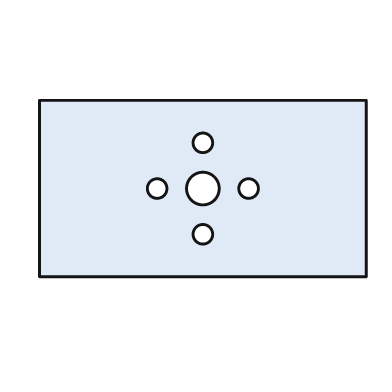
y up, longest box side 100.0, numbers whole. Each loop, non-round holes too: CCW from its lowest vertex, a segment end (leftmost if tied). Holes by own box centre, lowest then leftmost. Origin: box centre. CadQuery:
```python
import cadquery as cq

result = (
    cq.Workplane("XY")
    .moveTo(-50.0, -27.0)
    .lineTo(50.0, -27.0)
    .lineTo(50.0, 27.0)
    .lineTo(-50.0, 27.0)
    .close()
    .moveTo(0.0, -14.0)
    .circle(3.0)
    .moveTo(-14.0, 0.0)
    .circle(3.0)
    .moveTo(0.0, 0.0)
    .circle(5.0)
    .moveTo(14.0, 0.0)
    .circle(3.0)
    .moveTo(0.0, 14.0)
    .circle(3.0)
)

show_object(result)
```